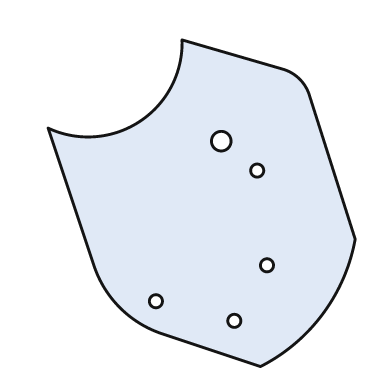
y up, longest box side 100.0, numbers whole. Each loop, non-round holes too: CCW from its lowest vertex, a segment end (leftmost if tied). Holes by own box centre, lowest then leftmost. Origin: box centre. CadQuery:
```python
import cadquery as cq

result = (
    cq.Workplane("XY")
    .moveTo(18.0, -50.0)
    .threePointArc((37.0, -34.0), (47.0, -11.0))
    .lineTo(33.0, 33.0)
    .threePointArc((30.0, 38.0), (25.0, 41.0))
    .lineTo(-6.0, 50.0)
    .threePointArc((-19.0, 25.0), (-47.0, 23.0))
    .lineTo(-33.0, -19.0)
    .threePointArc((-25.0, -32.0), (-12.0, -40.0))
    .close()
    .moveTo(10.0, -36.0)
    .circle(2.0)
    .moveTo(-14.0, -30.0)
    .circle(2.0)
    .moveTo(20.0, -19.0)
    .circle(2.0)
    .moveTo(17.0, 10.0)
    .circle(2.0)
    .moveTo(6.0, 19.0)
    .circle(3.0)
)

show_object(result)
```